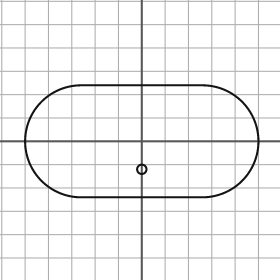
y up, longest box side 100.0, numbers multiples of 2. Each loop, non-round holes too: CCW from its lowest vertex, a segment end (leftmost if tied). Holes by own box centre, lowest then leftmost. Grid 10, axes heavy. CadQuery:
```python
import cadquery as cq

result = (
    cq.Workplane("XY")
    .moveTo(-26.0, -24.0)
    .lineTo(26.0, -24.0)
    .threePointArc((50.0, 0.0), (26.0, 24.0))
    .lineTo(-26.0, 24.0)
    .threePointArc((-50.0, 0.0), (-26.0, -24.0))
    .close()
    .moveTo(0.0, -12.0)
    .circle(2.0)
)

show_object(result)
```